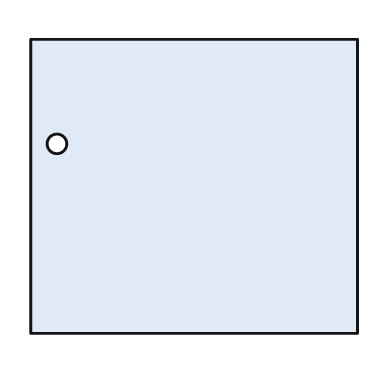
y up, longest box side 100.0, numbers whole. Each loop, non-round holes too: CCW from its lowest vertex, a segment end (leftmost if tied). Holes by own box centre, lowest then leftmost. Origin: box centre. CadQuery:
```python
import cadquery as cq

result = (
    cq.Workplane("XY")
    .moveTo(-50.0, -45.0)
    .lineTo(50.0, -45.0)
    .lineTo(50.0, 45.0)
    .lineTo(-50.0, 45.0)
    .close()
    .moveTo(-42.0, 13.0)
    .circle(3.0)
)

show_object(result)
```